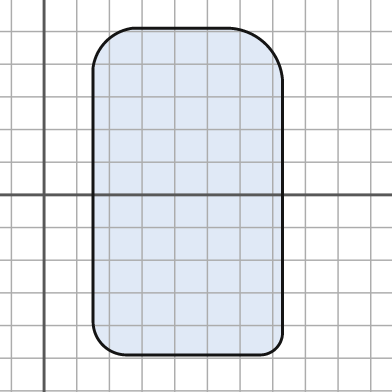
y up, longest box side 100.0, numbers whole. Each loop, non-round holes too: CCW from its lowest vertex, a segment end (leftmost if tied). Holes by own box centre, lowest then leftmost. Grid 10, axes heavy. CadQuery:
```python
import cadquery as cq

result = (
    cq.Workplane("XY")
    .moveTo(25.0, -49.0)
    .lineTo(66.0, -49.0)
    .threePointArc((71.0, -47.0), (73.0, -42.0))
    .lineTo(73.0, 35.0)
    .threePointArc((68.0, 46.0), (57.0, 51.0))
    .lineTo(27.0, 51.0)
    .threePointArc((19.0, 47.0), (15.0, 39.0))
    .lineTo(15.0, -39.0)
    .threePointArc((18.0, -46.0), (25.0, -49.0))
    .close()
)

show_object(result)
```